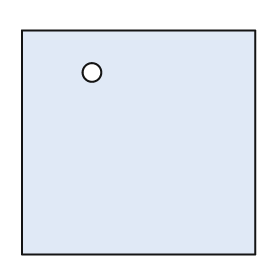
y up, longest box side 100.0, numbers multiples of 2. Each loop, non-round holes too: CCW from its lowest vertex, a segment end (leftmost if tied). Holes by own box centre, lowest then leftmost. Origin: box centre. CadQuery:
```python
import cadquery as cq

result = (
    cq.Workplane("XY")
    .moveTo(-50.0, -48.0)
    .lineTo(50.0, -48.0)
    .lineTo(50.0, 48.0)
    .lineTo(-50.0, 48.0)
    .close()
    .moveTo(-20.0, 30.0)
    .circle(4.0)
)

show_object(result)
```